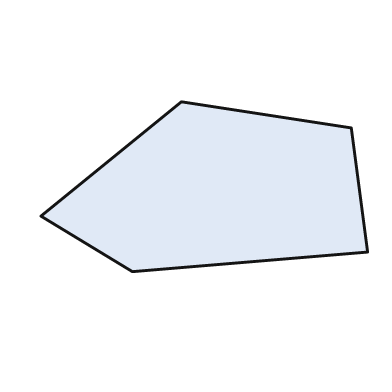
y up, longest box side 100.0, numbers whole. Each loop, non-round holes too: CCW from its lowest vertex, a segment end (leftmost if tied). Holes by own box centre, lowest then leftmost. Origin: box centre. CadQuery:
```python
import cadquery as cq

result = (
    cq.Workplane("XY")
    .moveTo(-22.0, -26.0)
    .lineTo(50.0, -20.0)
    .lineTo(45.0, 18.0)
    .lineTo(-7.0, 26.0)
    .lineTo(-50.0, -9.0)
    .close()
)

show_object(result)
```